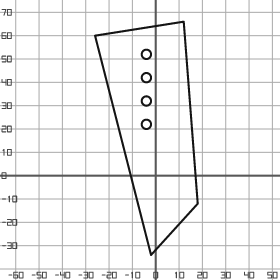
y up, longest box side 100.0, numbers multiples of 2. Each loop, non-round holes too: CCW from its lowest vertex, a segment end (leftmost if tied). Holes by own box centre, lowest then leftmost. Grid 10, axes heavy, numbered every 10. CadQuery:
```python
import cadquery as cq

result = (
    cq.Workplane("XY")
    .moveTo(-2.0, -34.0)
    .lineTo(18.0, -12.0)
    .lineTo(12.0, 66.0)
    .lineTo(-26.0, 60.0)
    .close()
    .moveTo(-4.0, 22.0)
    .circle(2.0)
    .moveTo(-4.0, 32.0)
    .circle(2.0)
    .moveTo(-4.0, 42.0)
    .circle(2.0)
    .moveTo(-4.0, 52.0)
    .circle(2.0)
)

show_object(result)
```